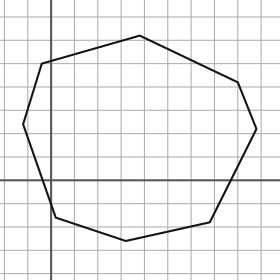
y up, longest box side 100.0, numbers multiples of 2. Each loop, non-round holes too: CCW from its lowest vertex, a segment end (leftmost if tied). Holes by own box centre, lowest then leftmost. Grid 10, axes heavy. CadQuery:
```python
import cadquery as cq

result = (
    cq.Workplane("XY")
    .moveTo(32.0, -26.0)
    .lineTo(68.0, -18.0)
    .lineTo(88.0, 22.0)
    .lineTo(80.0, 42.0)
    .lineTo(38.0, 62.0)
    .lineTo(-4.0, 50.0)
    .lineTo(-12.0, 24.0)
    .lineTo(2.0, -16.0)
    .close()
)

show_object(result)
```